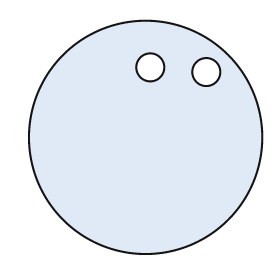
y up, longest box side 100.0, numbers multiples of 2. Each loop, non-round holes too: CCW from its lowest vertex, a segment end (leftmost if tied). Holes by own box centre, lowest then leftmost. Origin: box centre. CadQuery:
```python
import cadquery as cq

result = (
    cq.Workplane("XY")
    .moveTo(0.0, 0.0)
    .circle(50.0)
    .moveTo(26.0, 28.0)
    .circle(6.0)
    .moveTo(2.0, 30.0)
    .circle(6.0)
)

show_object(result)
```